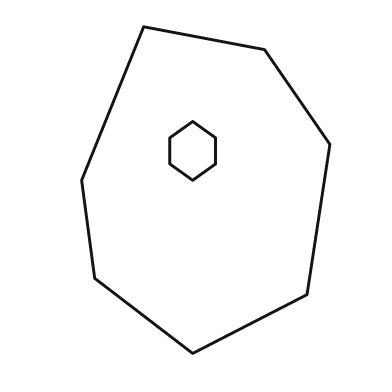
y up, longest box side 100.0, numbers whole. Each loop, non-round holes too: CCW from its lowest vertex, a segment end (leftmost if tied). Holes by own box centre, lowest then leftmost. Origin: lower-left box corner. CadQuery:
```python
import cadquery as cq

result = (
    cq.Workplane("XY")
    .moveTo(34.0, 0.0)
    .lineTo(69.0, 18.0)
    .lineTo(76.0, 64.0)
    .lineTo(56.0, 93.0)
    .lineTo(19.0, 100.0)
    .lineTo(0.0, 53.0)
    .lineTo(4.0, 23.0)
    .close()
    .moveTo(34.0, 53.0)
    .lineTo(41.0, 58.0)
    .lineTo(41.0, 66.0)
    .lineTo(34.0, 71.0)
    .lineTo(27.0, 66.0)
    .lineTo(27.0, 58.0)
    .close()
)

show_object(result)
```